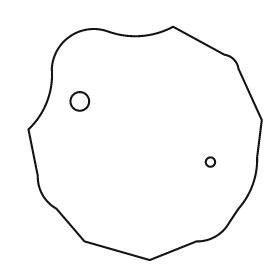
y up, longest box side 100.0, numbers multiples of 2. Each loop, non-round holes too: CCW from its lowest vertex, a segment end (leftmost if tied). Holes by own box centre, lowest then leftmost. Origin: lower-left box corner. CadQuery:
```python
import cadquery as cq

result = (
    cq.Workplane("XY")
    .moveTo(52.0, 0.0)
    .lineTo(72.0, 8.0)
    .threePointArc((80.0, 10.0), (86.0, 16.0))
    .lineTo(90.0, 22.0)
    .threePointArc((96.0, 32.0), (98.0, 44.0))
    .lineTo(100.0, 60.0)
    .lineTo(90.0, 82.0)
    .threePointArc((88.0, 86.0), (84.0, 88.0))
    .lineTo(62.0, 100.0)
    .threePointArc((48.0, 96.0), (34.0, 98.0))
    .threePointArc((18.0, 96.0), (10.0, 82.0))
    .threePointArc((8.0, 68.0), (0.0, 56.0))
    .lineTo(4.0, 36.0)
    .threePointArc((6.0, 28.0), (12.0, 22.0))
    .lineTo(24.0, 8.0)
    .close()
    .moveTo(78.0, 42.0)
    .circle(2.0)
    .moveTo(22.0, 68.0)
    .circle(4.0)
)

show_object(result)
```